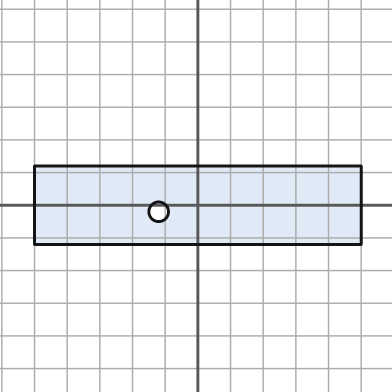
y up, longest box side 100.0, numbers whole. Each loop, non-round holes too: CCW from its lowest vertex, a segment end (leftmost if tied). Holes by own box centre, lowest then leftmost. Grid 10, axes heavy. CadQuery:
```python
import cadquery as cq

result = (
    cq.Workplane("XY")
    .moveTo(-50.0, -12.0)
    .lineTo(50.0, -12.0)
    .lineTo(50.0, 12.0)
    .lineTo(-50.0, 12.0)
    .close()
    .moveTo(-12.0, -2.0)
    .circle(3.0)
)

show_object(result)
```